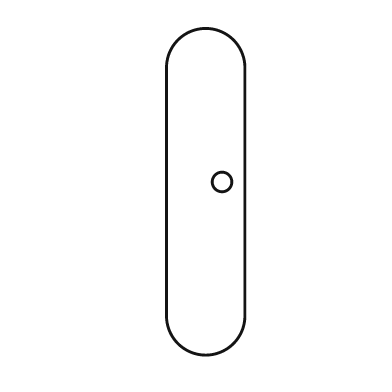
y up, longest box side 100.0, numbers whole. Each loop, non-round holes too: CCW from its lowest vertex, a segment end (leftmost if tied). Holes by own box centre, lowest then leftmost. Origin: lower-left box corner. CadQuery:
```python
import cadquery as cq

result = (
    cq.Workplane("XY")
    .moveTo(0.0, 12.0)
    .threePointArc((12.0, 0.0), (24.0, 12.0))
    .lineTo(24.0, 88.0)
    .threePointArc((12.0, 100.0), (0.0, 88.0))
    .close()
    .moveTo(17.0, 53.0)
    .circle(3.0)
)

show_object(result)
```